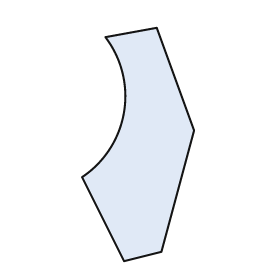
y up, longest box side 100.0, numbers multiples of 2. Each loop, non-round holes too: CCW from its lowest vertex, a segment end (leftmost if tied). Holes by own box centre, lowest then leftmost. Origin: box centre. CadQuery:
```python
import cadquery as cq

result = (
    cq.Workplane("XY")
    .moveTo(-6.0, -50.0)
    .lineTo(10.0, -46.0)
    .lineTo(24.0, 6.0)
    .lineTo(8.0, 50.0)
    .lineTo(-14.0, 46.0)
    .threePointArc((-6.0, 14.0), (-24.0, -14.0))
    .close()
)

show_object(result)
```